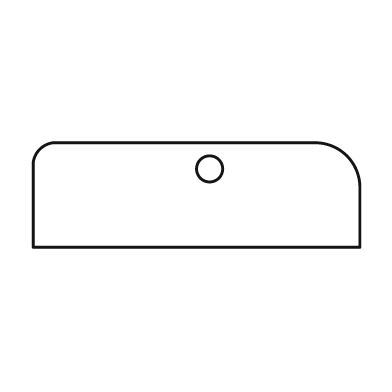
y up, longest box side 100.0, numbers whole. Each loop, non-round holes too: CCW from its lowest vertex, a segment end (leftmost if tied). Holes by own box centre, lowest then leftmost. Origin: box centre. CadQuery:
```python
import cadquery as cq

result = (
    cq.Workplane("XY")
    .moveTo(-50.0, -16.0)
    .lineTo(50.0, -16.0)
    .lineTo(50.0, 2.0)
    .threePointArc((46.0, 12.0), (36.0, 16.0))
    .lineTo(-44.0, 16.0)
    .threePointArc((-48.0, 14.0), (-50.0, 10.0))
    .close()
    .moveTo(4.0, 8.0)
    .circle(4.0)
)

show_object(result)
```